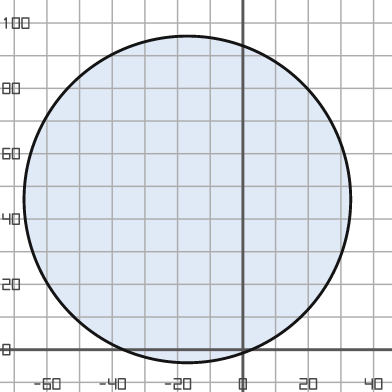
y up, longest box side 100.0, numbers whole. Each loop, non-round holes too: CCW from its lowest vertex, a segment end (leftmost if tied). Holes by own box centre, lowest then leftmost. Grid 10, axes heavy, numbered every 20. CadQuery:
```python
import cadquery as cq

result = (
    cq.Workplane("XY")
    .moveTo(-17.0, 46.0)
    .circle(50.0)
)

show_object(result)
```